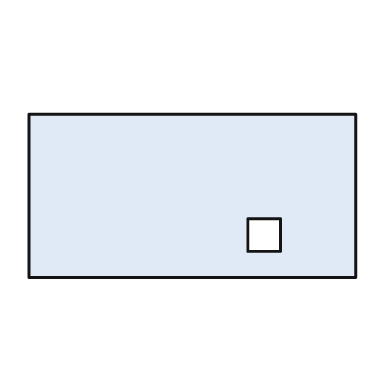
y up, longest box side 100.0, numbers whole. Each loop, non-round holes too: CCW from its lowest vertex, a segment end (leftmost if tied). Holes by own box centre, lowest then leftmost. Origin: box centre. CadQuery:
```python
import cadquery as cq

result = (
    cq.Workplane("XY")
    .moveTo(-50.0, -25.0)
    .lineTo(50.0, -25.0)
    .lineTo(50.0, 25.0)
    .lineTo(-50.0, 25.0)
    .close()
    .moveTo(17.0, -17.0)
    .lineTo(27.0, -17.0)
    .lineTo(27.0, -7.0)
    .lineTo(17.0, -7.0)
    .close()
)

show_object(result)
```